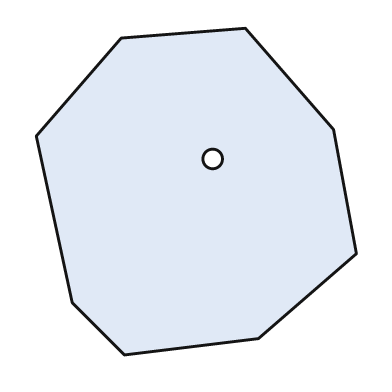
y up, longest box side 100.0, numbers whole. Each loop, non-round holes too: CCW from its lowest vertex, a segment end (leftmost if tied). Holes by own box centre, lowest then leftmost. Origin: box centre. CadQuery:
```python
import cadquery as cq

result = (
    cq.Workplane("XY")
    .moveTo(-22.0, -50.0)
    .lineTo(19.0, -45.0)
    .lineTo(49.0, -19.0)
    .lineTo(42.0, 19.0)
    .lineTo(15.0, 50.0)
    .lineTo(-23.0, 47.0)
    .lineTo(-49.0, 17.0)
    .lineTo(-38.0, -34.0)
    .close()
    .moveTo(5.0, 10.0)
    .circle(3.0)
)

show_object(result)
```